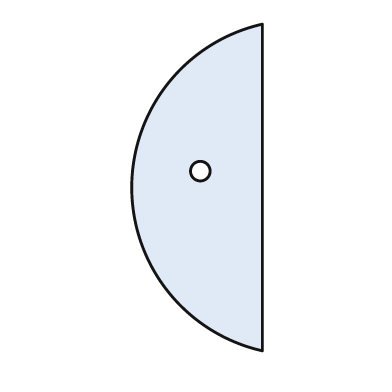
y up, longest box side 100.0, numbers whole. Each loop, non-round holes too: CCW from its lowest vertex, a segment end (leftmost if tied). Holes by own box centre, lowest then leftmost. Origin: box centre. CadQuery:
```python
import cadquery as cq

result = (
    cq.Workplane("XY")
    .moveTo(20.0, -50.0)
    .lineTo(20.0, 50.0)
    .threePointArc((-20.0, 0.0), (20.0, -50.0))
    .close()
    .moveTo(1.0, 5.0)
    .circle(3.0)
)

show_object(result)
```